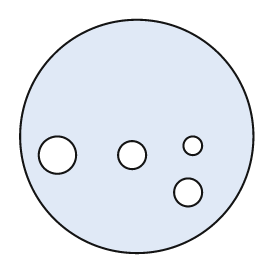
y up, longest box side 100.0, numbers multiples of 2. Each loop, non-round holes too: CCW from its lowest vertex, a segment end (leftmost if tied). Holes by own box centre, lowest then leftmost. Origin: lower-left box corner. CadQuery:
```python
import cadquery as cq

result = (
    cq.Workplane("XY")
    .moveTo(50.0, 50.0)
    .circle(50.0)
    .moveTo(72.0, 26.0)
    .circle(6.0)
    .moveTo(16.0, 42.0)
    .circle(8.0)
    .moveTo(48.0, 42.0)
    .circle(6.0)
    .moveTo(74.0, 46.0)
    .circle(4.0)
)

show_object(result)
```